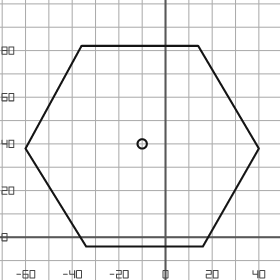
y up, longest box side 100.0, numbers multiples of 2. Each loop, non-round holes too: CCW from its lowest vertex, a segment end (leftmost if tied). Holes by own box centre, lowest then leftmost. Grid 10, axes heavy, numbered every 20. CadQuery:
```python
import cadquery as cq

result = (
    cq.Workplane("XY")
    .moveTo(-34.0, -4.0)
    .lineTo(16.0, -4.0)
    .lineTo(40.0, 38.0)
    .lineTo(14.0, 82.0)
    .lineTo(-36.0, 82.0)
    .lineTo(-60.0, 38.0)
    .close()
    .moveTo(-10.0, 40.0)
    .circle(2.0)
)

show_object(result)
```